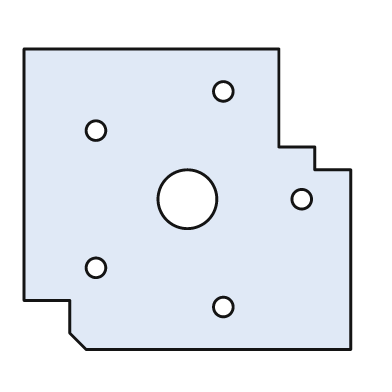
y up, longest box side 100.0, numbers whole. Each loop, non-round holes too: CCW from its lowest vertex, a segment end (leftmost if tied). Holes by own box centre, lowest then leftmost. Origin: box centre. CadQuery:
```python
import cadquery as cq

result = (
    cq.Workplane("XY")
    .moveTo(-31.0, -46.0)
    .lineTo(50.0, -46.0)
    .lineTo(50.0, 9.0)
    .lineTo(39.0, 9.0)
    .lineTo(39.0, 16.0)
    .lineTo(28.0, 16.0)
    .lineTo(28.0, 46.0)
    .lineTo(-50.0, 46.0)
    .lineTo(-50.0, -31.0)
    .lineTo(-36.0, -31.0)
    .lineTo(-36.0, -41.0)
    .close()
    .moveTo(11.0, -33.0)
    .circle(3.0)
    .moveTo(-28.0, -21.0)
    .circle(3.0)
    .moveTo(0.0, 0.0)
    .circle(9.0)
    .moveTo(35.0, 0.0)
    .circle(3.0)
    .moveTo(-28.0, 21.0)
    .circle(3.0)
    .moveTo(11.0, 33.0)
    .circle(3.0)
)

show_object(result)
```